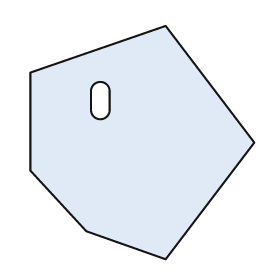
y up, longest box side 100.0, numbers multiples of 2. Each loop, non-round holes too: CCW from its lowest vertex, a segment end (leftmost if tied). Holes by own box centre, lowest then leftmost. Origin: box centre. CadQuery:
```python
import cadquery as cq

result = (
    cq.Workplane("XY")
    .moveTo(10.0, -50.0)
    .lineTo(48.0, 0.0)
    .lineTo(10.0, 50.0)
    .lineTo(-48.0, 30.0)
    .lineTo(-48.0, -12.0)
    .lineTo(-24.0, -38.0)
    .close()
    .moveTo(-22.0, 14.0)
    .threePointArc((-18.0, 10.0), (-14.0, 14.0))
    .lineTo(-14.0, 22.0)
    .threePointArc((-18.0, 26.0), (-22.0, 22.0))
    .close()
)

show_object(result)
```